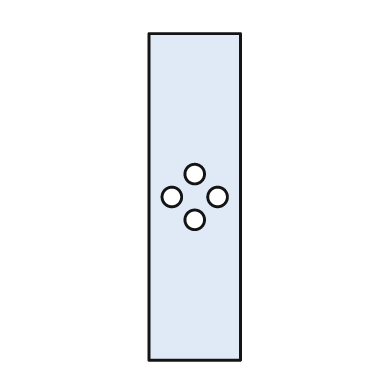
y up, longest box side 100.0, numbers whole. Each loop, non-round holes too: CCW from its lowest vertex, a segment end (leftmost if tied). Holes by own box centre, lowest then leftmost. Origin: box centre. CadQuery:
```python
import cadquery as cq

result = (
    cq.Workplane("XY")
    .moveTo(-14.0, -50.0)
    .lineTo(14.0, -50.0)
    .lineTo(14.0, 50.0)
    .lineTo(-14.0, 50.0)
    .close()
    .moveTo(0.0, -7.0)
    .circle(3.0)
    .moveTo(-7.0, 0.0)
    .circle(3.0)
    .moveTo(7.0, 0.0)
    .circle(3.0)
    .moveTo(0.0, 7.0)
    .circle(3.0)
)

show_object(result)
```